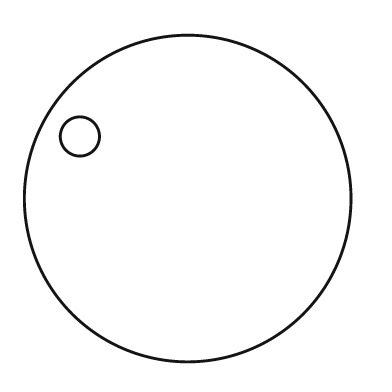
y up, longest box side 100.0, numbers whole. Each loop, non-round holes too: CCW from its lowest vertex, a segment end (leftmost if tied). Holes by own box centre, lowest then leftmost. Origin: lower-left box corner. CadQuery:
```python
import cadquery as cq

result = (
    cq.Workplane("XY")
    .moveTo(50.0, 50.0)
    .circle(50.0)
    .moveTo(17.0, 69.0)
    .circle(6.0)
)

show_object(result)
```